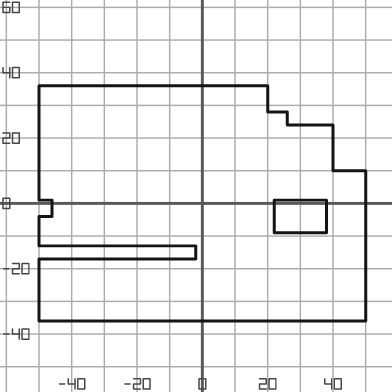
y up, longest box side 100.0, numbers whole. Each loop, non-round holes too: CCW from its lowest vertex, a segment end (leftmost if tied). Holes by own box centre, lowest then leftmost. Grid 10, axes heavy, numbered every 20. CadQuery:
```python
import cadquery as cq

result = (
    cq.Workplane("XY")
    .moveTo(-50.0, -36.0)
    .lineTo(50.0, -36.0)
    .lineTo(50.0, 10.0)
    .lineTo(40.0, 10.0)
    .lineTo(40.0, 24.0)
    .lineTo(26.0, 24.0)
    .lineTo(26.0, 28.0)
    .lineTo(20.0, 28.0)
    .lineTo(20.0, 36.0)
    .lineTo(-50.0, 36.0)
    .lineTo(-50.0, 1.0)
    .lineTo(-46.0, 1.0)
    .lineTo(-46.0, -4.0)
    .lineTo(-50.0, -4.0)
    .lineTo(-50.0, -13.0)
    .lineTo(-2.0, -13.0)
    .lineTo(-2.0, -17.0)
    .lineTo(-50.0, -17.0)
    .close()
    .moveTo(22.0, -9.0)
    .lineTo(38.0, -9.0)
    .lineTo(38.0, 1.0)
    .lineTo(22.0, 1.0)
    .close()
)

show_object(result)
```